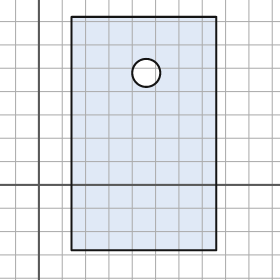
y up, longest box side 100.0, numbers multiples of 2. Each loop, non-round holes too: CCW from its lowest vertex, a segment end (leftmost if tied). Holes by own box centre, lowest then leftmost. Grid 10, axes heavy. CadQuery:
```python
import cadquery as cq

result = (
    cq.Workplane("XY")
    .moveTo(14.0, -28.0)
    .lineTo(76.0, -28.0)
    .lineTo(76.0, 72.0)
    .lineTo(14.0, 72.0)
    .close()
    .moveTo(46.0, 48.0)
    .circle(6.0)
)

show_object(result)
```